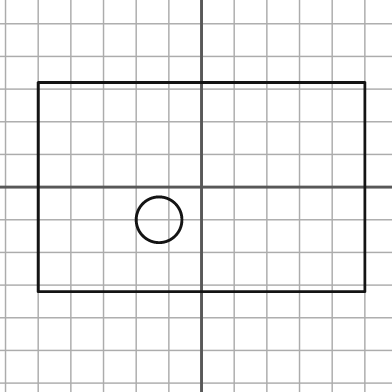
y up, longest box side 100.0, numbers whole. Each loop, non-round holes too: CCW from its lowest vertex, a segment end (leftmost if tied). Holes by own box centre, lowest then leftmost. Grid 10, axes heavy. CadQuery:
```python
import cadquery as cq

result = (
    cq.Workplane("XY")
    .moveTo(-50.0, -32.0)
    .lineTo(50.0, -32.0)
    .lineTo(50.0, 32.0)
    .lineTo(-50.0, 32.0)
    .close()
    .moveTo(-13.0, -10.0)
    .circle(7.0)
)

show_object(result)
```